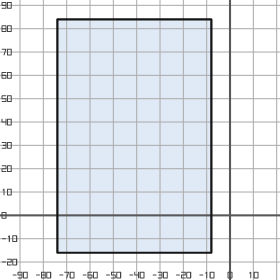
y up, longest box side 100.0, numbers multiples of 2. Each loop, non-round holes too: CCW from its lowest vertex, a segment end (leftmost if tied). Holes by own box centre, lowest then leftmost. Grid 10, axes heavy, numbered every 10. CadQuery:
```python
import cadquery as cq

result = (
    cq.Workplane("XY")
    .moveTo(-74.0, -16.0)
    .lineTo(-8.0, -16.0)
    .lineTo(-8.0, 84.0)
    .lineTo(-74.0, 84.0)
    .close()
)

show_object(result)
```